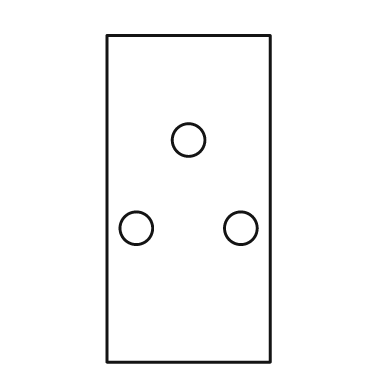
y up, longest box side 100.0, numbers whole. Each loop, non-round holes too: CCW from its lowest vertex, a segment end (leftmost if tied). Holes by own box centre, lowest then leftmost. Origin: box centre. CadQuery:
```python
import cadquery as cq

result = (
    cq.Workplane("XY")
    .moveTo(-25.0, -50.0)
    .lineTo(25.0, -50.0)
    .lineTo(25.0, 50.0)
    .lineTo(-25.0, 50.0)
    .close()
    .moveTo(-16.0, -9.0)
    .circle(5.0)
    .moveTo(16.0, -9.0)
    .circle(5.0)
    .moveTo(0.0, 18.0)
    .circle(5.0)
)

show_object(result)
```